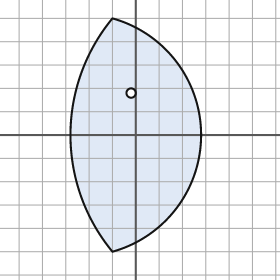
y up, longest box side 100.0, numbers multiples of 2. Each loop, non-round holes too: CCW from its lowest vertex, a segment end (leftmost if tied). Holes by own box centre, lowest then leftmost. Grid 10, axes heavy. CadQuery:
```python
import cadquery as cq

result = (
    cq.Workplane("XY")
    .moveTo(-10.0, -50.0)
    .threePointArc((28.0, 0.0), (-10.0, 50.0))
    .threePointArc((-28.0, 0.0), (-10.0, -50.0))
    .close()
    .moveTo(-2.0, 18.0)
    .circle(2.0)
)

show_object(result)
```